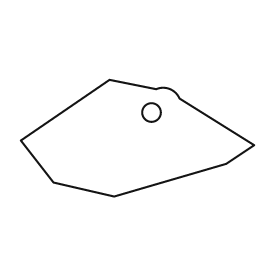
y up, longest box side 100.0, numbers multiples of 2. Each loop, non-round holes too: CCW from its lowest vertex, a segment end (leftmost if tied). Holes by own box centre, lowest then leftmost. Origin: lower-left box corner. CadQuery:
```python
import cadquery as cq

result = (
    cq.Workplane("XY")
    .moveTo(40.0, 0.0)
    .lineTo(88.0, 14.0)
    .lineTo(100.0, 22.0)
    .lineTo(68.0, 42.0)
    .threePointArc((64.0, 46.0), (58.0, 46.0))
    .lineTo(38.0, 50.0)
    .lineTo(0.0, 24.0)
    .lineTo(14.0, 6.0)
    .close()
    .moveTo(56.0, 36.0)
    .circle(4.0)
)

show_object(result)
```